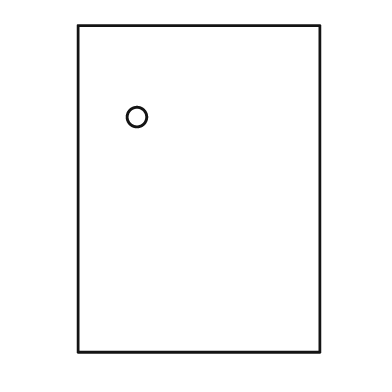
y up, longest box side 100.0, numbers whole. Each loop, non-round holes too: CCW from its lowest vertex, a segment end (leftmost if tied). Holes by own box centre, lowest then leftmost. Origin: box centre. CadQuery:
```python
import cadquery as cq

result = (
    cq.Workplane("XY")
    .moveTo(-37.0, -50.0)
    .lineTo(37.0, -50.0)
    .lineTo(37.0, 50.0)
    .lineTo(-37.0, 50.0)
    .close()
    .moveTo(-19.0, 22.0)
    .circle(3.0)
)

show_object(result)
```